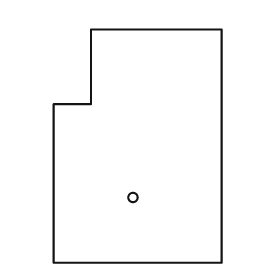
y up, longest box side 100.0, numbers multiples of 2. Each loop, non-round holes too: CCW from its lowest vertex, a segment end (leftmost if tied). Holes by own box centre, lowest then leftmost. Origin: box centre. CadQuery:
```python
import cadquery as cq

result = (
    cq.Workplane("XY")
    .moveTo(-36.0, -50.0)
    .lineTo(36.0, -50.0)
    .lineTo(36.0, 50.0)
    .lineTo(-20.0, 50.0)
    .lineTo(-20.0, 18.0)
    .lineTo(-36.0, 18.0)
    .close()
    .moveTo(-2.0, -22.0)
    .circle(2.0)
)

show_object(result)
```